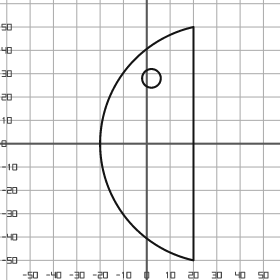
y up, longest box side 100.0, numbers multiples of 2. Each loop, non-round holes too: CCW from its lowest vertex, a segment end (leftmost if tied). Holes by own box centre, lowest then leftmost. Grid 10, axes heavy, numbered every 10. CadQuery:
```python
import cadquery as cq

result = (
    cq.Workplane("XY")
    .moveTo(20.0, -50.0)
    .lineTo(20.0, 50.0)
    .threePointArc((-20.0, 0.0), (20.0, -50.0))
    .close()
    .moveTo(2.0, 28.0)
    .circle(4.0)
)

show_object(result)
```